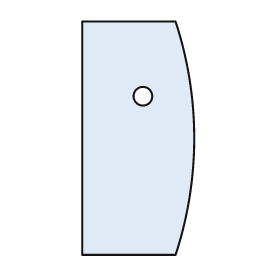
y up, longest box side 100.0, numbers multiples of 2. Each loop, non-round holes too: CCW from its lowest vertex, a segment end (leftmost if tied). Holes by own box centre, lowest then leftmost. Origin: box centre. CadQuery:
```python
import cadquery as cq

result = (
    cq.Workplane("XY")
    .moveTo(-24.0, -50.0)
    .lineTo(16.0, -50.0)
    .threePointArc((24.0, 0.0), (16.0, 50.0))
    .lineTo(-24.0, 50.0)
    .close()
    .moveTo(2.0, 18.0)
    .circle(4.0)
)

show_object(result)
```